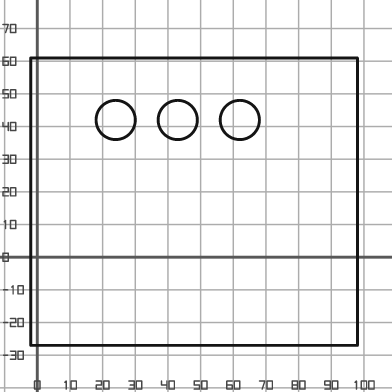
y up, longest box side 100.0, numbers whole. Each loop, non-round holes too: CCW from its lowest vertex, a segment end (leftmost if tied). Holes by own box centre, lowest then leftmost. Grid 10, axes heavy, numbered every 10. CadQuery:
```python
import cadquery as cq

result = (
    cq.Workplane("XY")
    .moveTo(-2.0, -27.0)
    .lineTo(98.0, -27.0)
    .lineTo(98.0, 61.0)
    .lineTo(-2.0, 61.0)
    .close()
    .moveTo(24.0, 42.0)
    .circle(6.0)
    .moveTo(43.0, 42.0)
    .circle(6.0)
    .moveTo(62.0, 42.0)
    .circle(6.0)
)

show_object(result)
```